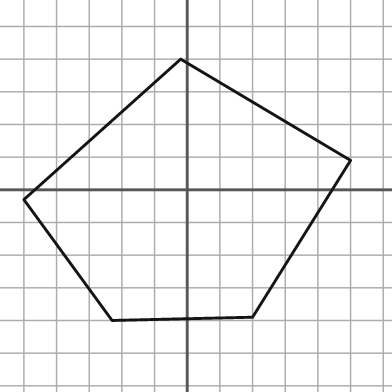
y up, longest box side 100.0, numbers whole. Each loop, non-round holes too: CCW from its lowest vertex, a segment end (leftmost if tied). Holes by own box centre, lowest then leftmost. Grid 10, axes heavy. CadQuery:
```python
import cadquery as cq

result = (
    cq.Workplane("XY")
    .moveTo(-23.0, -40.0)
    .lineTo(20.0, -39.0)
    .lineTo(50.0, 9.0)
    .lineTo(-2.0, 40.0)
    .lineTo(-50.0, -3.0)
    .close()
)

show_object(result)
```